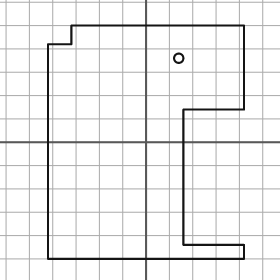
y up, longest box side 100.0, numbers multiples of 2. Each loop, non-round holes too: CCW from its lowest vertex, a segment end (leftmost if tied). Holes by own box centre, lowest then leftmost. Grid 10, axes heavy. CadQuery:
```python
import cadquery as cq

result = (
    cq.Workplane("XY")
    .moveTo(-42.0, -50.0)
    .lineTo(42.0, -50.0)
    .lineTo(42.0, -44.0)
    .lineTo(16.0, -44.0)
    .lineTo(16.0, 14.0)
    .lineTo(42.0, 14.0)
    .lineTo(42.0, 50.0)
    .lineTo(-32.0, 50.0)
    .lineTo(-32.0, 42.0)
    .lineTo(-42.0, 42.0)
    .close()
    .moveTo(14.0, 36.0)
    .circle(2.0)
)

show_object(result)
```